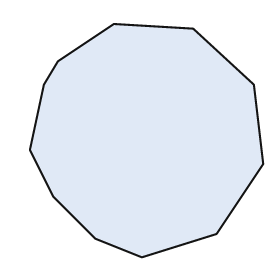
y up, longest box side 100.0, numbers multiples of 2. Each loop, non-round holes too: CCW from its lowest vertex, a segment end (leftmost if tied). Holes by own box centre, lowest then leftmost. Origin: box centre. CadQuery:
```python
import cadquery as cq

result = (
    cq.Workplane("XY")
    .moveTo(-2.0, -50.0)
    .lineTo(30.0, -40.0)
    .lineTo(50.0, -10.0)
    .lineTo(46.0, 24.0)
    .lineTo(20.0, 48.0)
    .lineTo(-14.0, 50.0)
    .lineTo(-38.0, 34.0)
    .lineTo(-44.0, 24.0)
    .lineTo(-50.0, -4.0)
    .lineTo(-40.0, -24.0)
    .lineTo(-22.0, -42.0)
    .close()
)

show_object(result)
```